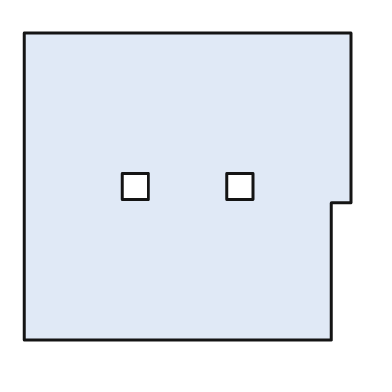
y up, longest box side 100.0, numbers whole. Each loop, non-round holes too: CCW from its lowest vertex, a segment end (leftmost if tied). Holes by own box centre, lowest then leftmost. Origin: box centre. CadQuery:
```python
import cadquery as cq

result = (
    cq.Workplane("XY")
    .moveTo(-50.0, -47.0)
    .lineTo(44.0, -47.0)
    .lineTo(44.0, -5.0)
    .lineTo(50.0, -5.0)
    .lineTo(50.0, 47.0)
    .lineTo(-50.0, 47.0)
    .close()
    .moveTo(-20.0, -4.0)
    .lineTo(-12.0, -4.0)
    .lineTo(-12.0, 4.0)
    .lineTo(-20.0, 4.0)
    .close()
    .moveTo(12.0, -4.0)
    .lineTo(20.0, -4.0)
    .lineTo(20.0, 4.0)
    .lineTo(12.0, 4.0)
    .close()
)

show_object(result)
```